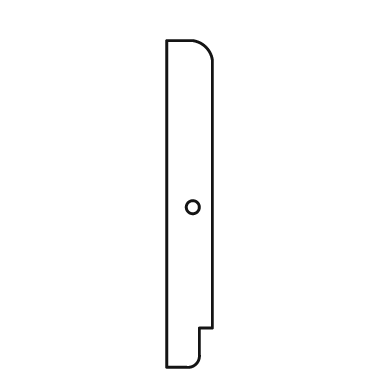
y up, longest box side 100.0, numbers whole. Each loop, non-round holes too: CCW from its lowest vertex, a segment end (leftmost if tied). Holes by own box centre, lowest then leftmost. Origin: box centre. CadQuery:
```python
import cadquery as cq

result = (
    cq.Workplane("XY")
    .moveTo(-7.0, -50.0)
    .lineTo(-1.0, -50.0)
    .threePointArc((2.0, -49.0), (3.0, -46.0))
    .lineTo(3.0, -38.0)
    .lineTo(7.0, -38.0)
    .lineTo(7.0, 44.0)
    .threePointArc((5.0, 48.0), (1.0, 50.0))
    .lineTo(-7.0, 50.0)
    .close()
    .moveTo(1.0, -1.0)
    .circle(2.0)
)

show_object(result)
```